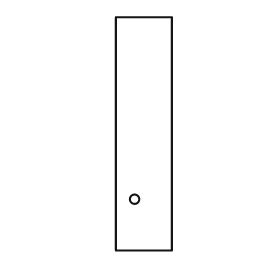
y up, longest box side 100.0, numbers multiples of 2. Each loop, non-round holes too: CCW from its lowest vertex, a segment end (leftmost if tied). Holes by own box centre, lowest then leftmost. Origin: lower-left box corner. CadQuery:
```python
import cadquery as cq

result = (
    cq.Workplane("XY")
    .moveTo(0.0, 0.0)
    .lineTo(24.0, 0.0)
    .lineTo(24.0, 100.0)
    .lineTo(0.0, 100.0)
    .close()
    .moveTo(8.0, 22.0)
    .circle(2.0)
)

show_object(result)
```